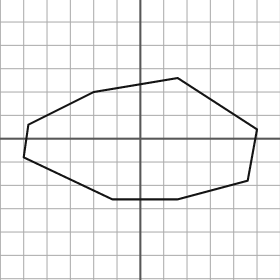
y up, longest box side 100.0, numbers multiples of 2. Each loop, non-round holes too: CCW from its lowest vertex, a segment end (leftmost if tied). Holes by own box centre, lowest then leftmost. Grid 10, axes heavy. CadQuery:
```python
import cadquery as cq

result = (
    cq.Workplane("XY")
    .moveTo(-12.0, -26.0)
    .lineTo(16.0, -26.0)
    .lineTo(46.0, -18.0)
    .lineTo(50.0, 4.0)
    .lineTo(16.0, 26.0)
    .lineTo(-20.0, 20.0)
    .lineTo(-48.0, 6.0)
    .lineTo(-50.0, -8.0)
    .close()
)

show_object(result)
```